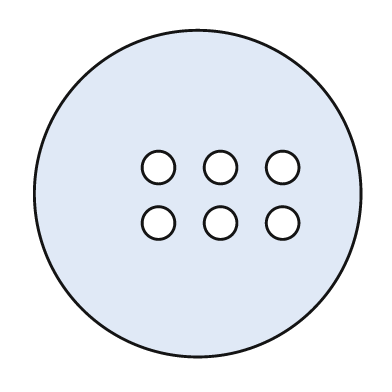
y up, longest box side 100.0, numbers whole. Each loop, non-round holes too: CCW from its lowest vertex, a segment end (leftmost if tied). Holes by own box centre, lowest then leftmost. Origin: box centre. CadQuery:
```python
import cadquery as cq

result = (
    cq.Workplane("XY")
    .moveTo(0.0, 0.0)
    .circle(50.0)
    .moveTo(-12.0, -9.0)
    .circle(5.0)
    .moveTo(7.0, -9.0)
    .circle(5.0)
    .moveTo(26.0, -9.0)
    .circle(5.0)
    .moveTo(-12.0, 8.0)
    .circle(5.0)
    .moveTo(7.0, 8.0)
    .circle(5.0)
    .moveTo(26.0, 8.0)
    .circle(5.0)
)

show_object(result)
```